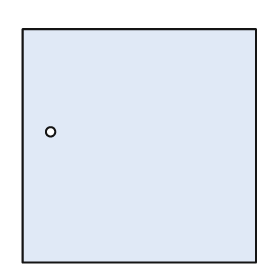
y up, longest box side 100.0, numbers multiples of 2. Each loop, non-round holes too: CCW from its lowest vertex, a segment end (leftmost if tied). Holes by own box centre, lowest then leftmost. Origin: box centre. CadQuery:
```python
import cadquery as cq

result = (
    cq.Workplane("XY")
    .moveTo(-50.0, -50.0)
    .lineTo(50.0, -50.0)
    .lineTo(50.0, 50.0)
    .lineTo(-50.0, 50.0)
    .close()
    .moveTo(-38.0, 6.0)
    .circle(2.0)
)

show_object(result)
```